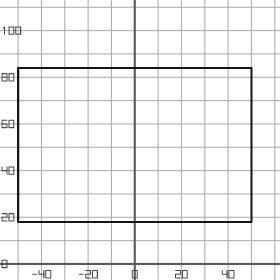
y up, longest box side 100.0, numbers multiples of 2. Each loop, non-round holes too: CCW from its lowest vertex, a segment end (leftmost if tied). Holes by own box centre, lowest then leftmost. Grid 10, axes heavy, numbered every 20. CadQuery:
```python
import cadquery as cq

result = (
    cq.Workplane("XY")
    .moveTo(-50.0, 18.0)
    .lineTo(50.0, 18.0)
    .lineTo(50.0, 84.0)
    .lineTo(-50.0, 84.0)
    .close()
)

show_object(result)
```